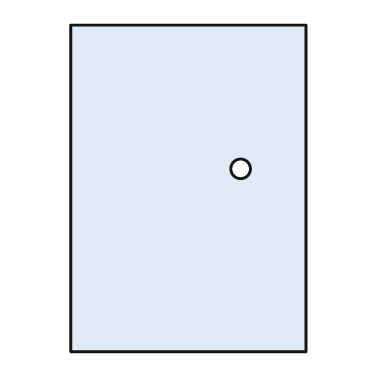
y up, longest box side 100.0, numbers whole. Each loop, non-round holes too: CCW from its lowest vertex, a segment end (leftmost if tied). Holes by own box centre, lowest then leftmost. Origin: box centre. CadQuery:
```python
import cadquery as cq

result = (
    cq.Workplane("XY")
    .moveTo(-36.0, -50.0)
    .lineTo(36.0, -50.0)
    .lineTo(36.0, 50.0)
    .lineTo(-36.0, 50.0)
    .close()
    .moveTo(16.0, 6.0)
    .circle(3.0)
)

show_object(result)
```